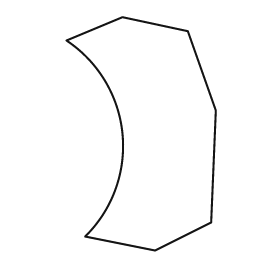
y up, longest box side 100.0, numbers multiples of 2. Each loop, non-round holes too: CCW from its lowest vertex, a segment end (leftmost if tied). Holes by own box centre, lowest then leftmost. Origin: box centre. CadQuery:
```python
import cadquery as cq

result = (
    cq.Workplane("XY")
    .moveTo(6.0, -50.0)
    .lineTo(30.0, -38.0)
    .lineTo(32.0, 10.0)
    .lineTo(20.0, 44.0)
    .lineTo(-8.0, 50.0)
    .lineTo(-32.0, 40.0)
    .threePointArc((-8.0, 0.0), (-24.0, -44.0))
    .close()
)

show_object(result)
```